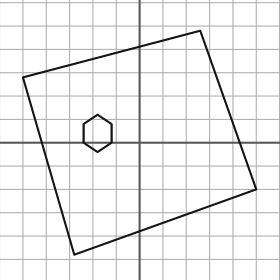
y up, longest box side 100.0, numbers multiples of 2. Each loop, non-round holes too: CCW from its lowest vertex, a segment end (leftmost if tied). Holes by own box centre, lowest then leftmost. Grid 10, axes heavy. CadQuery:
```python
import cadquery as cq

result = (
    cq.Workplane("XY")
    .moveTo(-28.0, -48.0)
    .lineTo(50.0, -20.0)
    .lineTo(26.0, 48.0)
    .lineTo(-50.0, 28.0)
    .close()
    .moveTo(-18.0, -4.0)
    .lineTo(-12.0, 0.0)
    .lineTo(-12.0, 8.0)
    .lineTo(-18.0, 12.0)
    .lineTo(-24.0, 8.0)
    .lineTo(-24.0, 0.0)
    .close()
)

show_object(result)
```